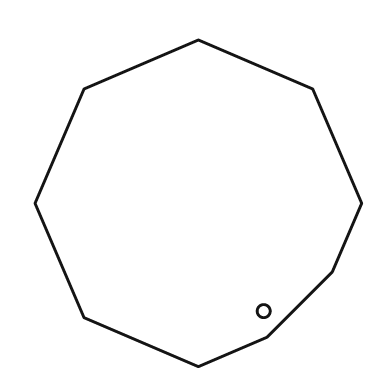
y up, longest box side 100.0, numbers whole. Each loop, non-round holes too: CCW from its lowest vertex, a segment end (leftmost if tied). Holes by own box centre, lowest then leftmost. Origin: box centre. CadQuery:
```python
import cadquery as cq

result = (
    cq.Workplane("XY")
    .moveTo(0.0, -50.0)
    .lineTo(21.0, -41.0)
    .lineTo(41.0, -21.0)
    .lineTo(50.0, 0.0)
    .lineTo(35.0, 35.0)
    .lineTo(0.0, 50.0)
    .lineTo(-35.0, 35.0)
    .lineTo(-50.0, 0.0)
    .lineTo(-35.0, -35.0)
    .close()
    .moveTo(20.0, -33.0)
    .circle(2.0)
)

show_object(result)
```